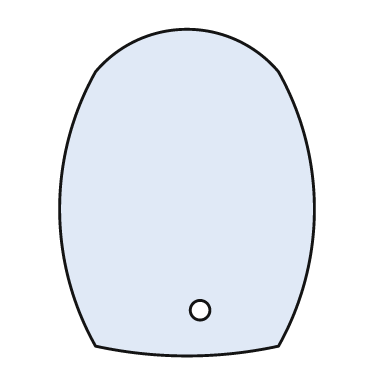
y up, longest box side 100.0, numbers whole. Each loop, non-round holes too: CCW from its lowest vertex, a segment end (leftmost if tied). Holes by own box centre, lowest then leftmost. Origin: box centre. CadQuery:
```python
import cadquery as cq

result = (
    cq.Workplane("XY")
    .moveTo(-28.0, -47.0)
    .threePointArc((0.0, -50.0), (28.0, -47.0))
    .threePointArc((39.0, -5.0), (28.0, 37.0))
    .threePointArc((0.0, 50.0), (-28.0, 37.0))
    .threePointArc((-39.0, -5.0), (-28.0, -47.0))
    .close()
    .moveTo(4.0, -36.0)
    .circle(3.0)
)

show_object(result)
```